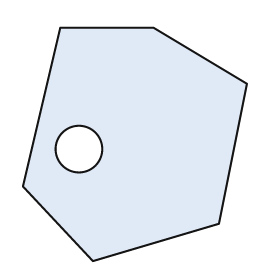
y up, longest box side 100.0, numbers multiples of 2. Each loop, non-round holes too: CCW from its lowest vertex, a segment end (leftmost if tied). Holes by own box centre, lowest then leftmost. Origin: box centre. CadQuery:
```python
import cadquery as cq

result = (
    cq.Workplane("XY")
    .moveTo(-18.0, -50.0)
    .lineTo(36.0, -34.0)
    .lineTo(48.0, 26.0)
    .lineTo(8.0, 50.0)
    .lineTo(-32.0, 50.0)
    .lineTo(-48.0, -18.0)
    .close()
    .moveTo(-24.0, -2.0)
    .circle(10.0)
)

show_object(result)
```